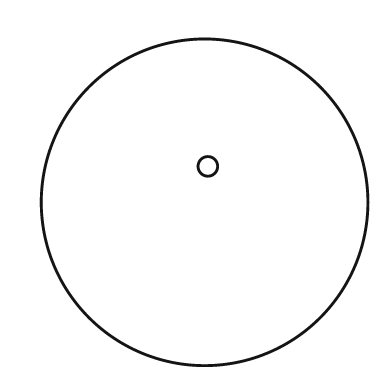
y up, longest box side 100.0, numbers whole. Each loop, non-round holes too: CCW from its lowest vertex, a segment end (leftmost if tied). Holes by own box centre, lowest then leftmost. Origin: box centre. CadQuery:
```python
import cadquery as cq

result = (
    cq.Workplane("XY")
    .moveTo(0.0, 0.0)
    .circle(50.0)
    .moveTo(1.0, 11.0)
    .circle(3.0)
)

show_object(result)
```